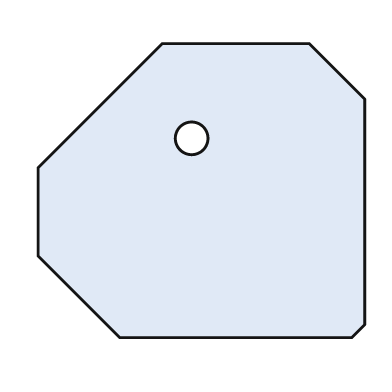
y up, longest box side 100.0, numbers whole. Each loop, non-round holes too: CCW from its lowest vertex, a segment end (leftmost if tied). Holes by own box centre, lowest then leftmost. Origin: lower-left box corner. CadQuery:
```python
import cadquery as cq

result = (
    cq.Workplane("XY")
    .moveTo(25.0, 0.0)
    .lineTo(96.0, 0.0)
    .lineTo(100.0, 4.0)
    .lineTo(100.0, 73.0)
    .lineTo(83.0, 90.0)
    .lineTo(38.0, 90.0)
    .lineTo(0.0, 52.0)
    .lineTo(0.0, 25.0)
    .close()
    .moveTo(47.0, 61.0)
    .circle(5.0)
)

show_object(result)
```